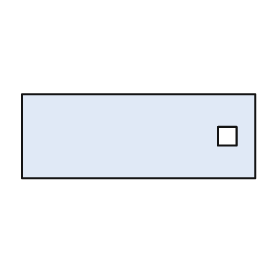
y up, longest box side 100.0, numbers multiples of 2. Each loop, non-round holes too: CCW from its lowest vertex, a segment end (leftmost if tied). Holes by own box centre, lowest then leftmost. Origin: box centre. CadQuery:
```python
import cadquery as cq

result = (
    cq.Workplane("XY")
    .moveTo(-50.0, -18.0)
    .lineTo(50.0, -18.0)
    .lineTo(50.0, 18.0)
    .lineTo(-50.0, 18.0)
    .close()
    .moveTo(34.0, -4.0)
    .lineTo(42.0, -4.0)
    .lineTo(42.0, 4.0)
    .lineTo(34.0, 4.0)
    .close()
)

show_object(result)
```